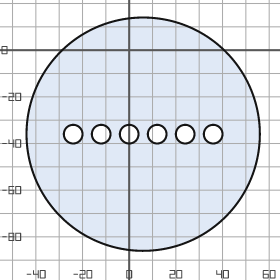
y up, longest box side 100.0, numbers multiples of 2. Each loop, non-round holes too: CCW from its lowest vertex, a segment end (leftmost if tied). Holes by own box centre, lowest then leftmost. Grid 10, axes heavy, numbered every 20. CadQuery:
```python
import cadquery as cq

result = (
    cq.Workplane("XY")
    .moveTo(6.0, -36.0)
    .circle(50.0)
    .moveTo(-24.0, -36.0)
    .circle(4.0)
    .moveTo(-12.0, -36.0)
    .circle(4.0)
    .moveTo(0.0, -36.0)
    .circle(4.0)
    .moveTo(12.0, -36.0)
    .circle(4.0)
    .moveTo(24.0, -36.0)
    .circle(4.0)
    .moveTo(36.0, -36.0)
    .circle(4.0)
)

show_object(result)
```